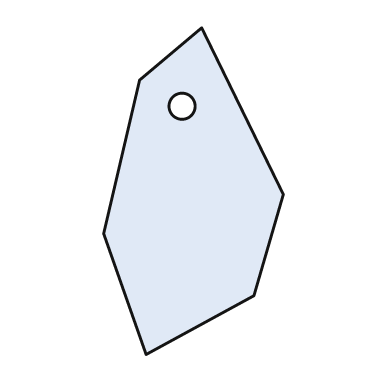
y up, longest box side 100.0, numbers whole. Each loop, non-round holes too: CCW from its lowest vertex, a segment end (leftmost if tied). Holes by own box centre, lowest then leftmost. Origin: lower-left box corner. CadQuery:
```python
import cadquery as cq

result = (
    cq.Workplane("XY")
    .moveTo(13.0, 0.0)
    .lineTo(46.0, 18.0)
    .lineTo(55.0, 49.0)
    .lineTo(30.0, 100.0)
    .lineTo(11.0, 84.0)
    .lineTo(0.0, 37.0)
    .close()
    .moveTo(24.0, 76.0)
    .circle(4.0)
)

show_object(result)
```